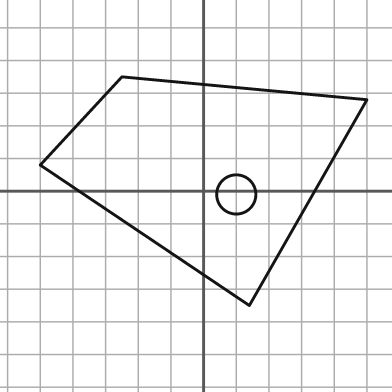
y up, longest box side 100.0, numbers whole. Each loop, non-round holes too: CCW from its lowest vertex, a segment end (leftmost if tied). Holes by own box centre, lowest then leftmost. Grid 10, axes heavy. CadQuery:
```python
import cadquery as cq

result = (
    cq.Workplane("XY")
    .moveTo(14.0, -35.0)
    .lineTo(50.0, 28.0)
    .lineTo(-25.0, 35.0)
    .lineTo(-50.0, 8.0)
    .close()
    .moveTo(10.0, -1.0)
    .circle(6.0)
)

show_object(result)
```